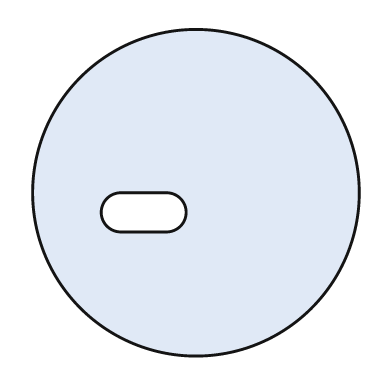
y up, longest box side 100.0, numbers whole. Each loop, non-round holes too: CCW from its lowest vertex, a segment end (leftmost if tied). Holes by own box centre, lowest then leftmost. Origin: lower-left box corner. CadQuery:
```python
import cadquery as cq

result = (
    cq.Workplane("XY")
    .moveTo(50.0, 50.0)
    .circle(50.0)
    .moveTo(27.0, 38.0)
    .lineTo(41.0, 38.0)
    .threePointArc((47.0, 44.0), (41.0, 50.0))
    .lineTo(27.0, 50.0)
    .threePointArc((21.0, 44.0), (27.0, 38.0))
    .close()
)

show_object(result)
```